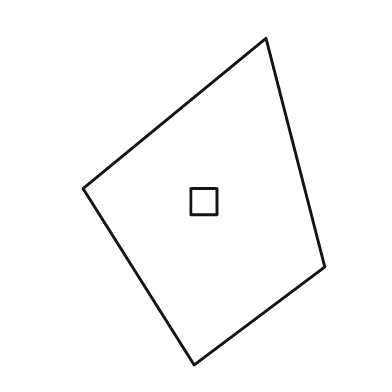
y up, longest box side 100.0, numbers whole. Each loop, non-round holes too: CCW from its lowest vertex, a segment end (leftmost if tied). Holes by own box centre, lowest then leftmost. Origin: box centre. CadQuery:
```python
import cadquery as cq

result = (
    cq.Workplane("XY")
    .moveTo(-3.0, -50.0)
    .lineTo(37.0, -20.0)
    .lineTo(19.0, 50.0)
    .lineTo(-37.0, 4.0)
    .close()
    .moveTo(-4.0, -4.0)
    .lineTo(4.0, -4.0)
    .lineTo(4.0, 4.0)
    .lineTo(-4.0, 4.0)
    .close()
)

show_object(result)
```